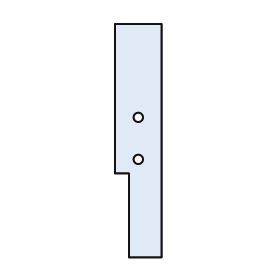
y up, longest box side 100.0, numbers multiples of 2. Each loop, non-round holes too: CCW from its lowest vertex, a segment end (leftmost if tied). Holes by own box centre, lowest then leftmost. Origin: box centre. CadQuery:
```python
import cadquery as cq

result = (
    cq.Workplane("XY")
    .moveTo(-4.0, -50.0)
    .lineTo(10.0, -50.0)
    .lineTo(10.0, 50.0)
    .lineTo(-10.0, 50.0)
    .lineTo(-10.0, -14.0)
    .lineTo(-4.0, -14.0)
    .close()
    .moveTo(0.0, -8.0)
    .circle(2.0)
    .moveTo(0.0, 10.0)
    .circle(2.0)
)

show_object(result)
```